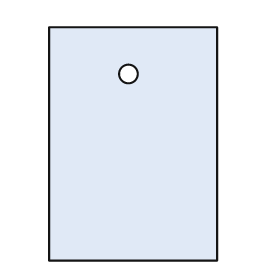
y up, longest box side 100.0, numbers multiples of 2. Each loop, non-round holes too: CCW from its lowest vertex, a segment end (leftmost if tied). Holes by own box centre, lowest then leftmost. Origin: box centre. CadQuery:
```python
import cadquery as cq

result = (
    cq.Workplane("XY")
    .moveTo(-36.0, -50.0)
    .lineTo(36.0, -50.0)
    .lineTo(36.0, 50.0)
    .lineTo(-36.0, 50.0)
    .close()
    .moveTo(-2.0, 30.0)
    .circle(4.0)
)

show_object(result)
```